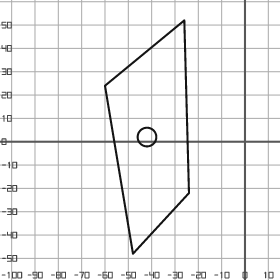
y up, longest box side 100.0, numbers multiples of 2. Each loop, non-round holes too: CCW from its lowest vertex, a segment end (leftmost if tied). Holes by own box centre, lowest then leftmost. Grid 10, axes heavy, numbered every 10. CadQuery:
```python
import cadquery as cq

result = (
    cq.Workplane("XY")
    .moveTo(-48.0, -48.0)
    .lineTo(-24.0, -22.0)
    .lineTo(-26.0, 52.0)
    .lineTo(-60.0, 24.0)
    .close()
    .moveTo(-42.0, 2.0)
    .circle(4.0)
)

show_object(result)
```